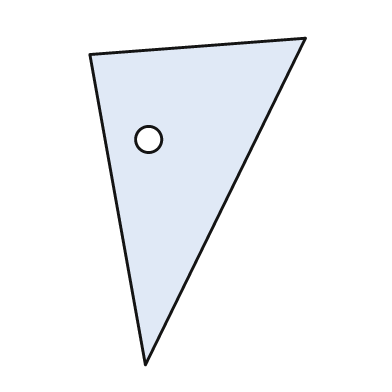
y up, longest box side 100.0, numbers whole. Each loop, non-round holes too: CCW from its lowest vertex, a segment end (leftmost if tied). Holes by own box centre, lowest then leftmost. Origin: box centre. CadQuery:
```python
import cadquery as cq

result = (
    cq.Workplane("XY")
    .moveTo(-16.0, -50.0)
    .lineTo(33.0, 50.0)
    .lineTo(-33.0, 45.0)
    .close()
    .moveTo(-15.0, 19.0)
    .circle(4.0)
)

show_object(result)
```